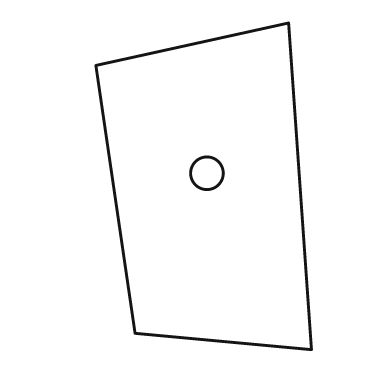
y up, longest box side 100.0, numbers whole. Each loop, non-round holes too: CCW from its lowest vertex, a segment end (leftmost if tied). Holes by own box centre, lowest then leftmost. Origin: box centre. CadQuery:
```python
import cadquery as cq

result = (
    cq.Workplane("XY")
    .moveTo(33.0, -50.0)
    .lineTo(26.0, 50.0)
    .lineTo(-33.0, 37.0)
    .lineTo(-21.0, -45.0)
    .close()
    .moveTo(1.0, 4.0)
    .circle(5.0)
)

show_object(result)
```